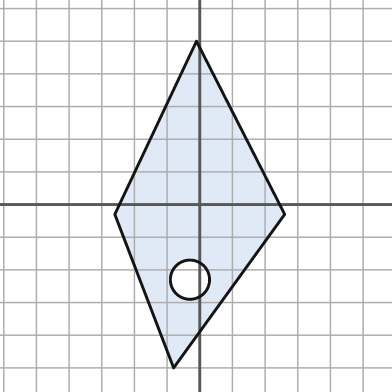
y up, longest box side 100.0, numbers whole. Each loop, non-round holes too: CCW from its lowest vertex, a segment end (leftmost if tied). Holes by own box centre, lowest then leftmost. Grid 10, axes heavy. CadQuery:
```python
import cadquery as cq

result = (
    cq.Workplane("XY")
    .moveTo(-8.0, -50.0)
    .lineTo(26.0, -3.0)
    .lineTo(-1.0, 50.0)
    .lineTo(-26.0, -3.0)
    .close()
    .moveTo(-3.0, -23.0)
    .circle(6.0)
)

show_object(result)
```